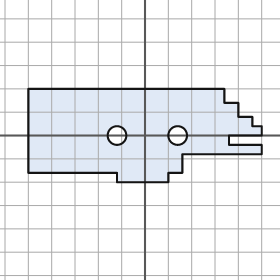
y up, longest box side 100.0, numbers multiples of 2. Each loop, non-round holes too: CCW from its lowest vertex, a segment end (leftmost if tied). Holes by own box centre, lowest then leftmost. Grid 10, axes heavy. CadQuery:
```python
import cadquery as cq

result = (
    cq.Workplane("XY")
    .moveTo(-12.0, -20.0)
    .lineTo(10.0, -20.0)
    .lineTo(10.0, -16.0)
    .lineTo(16.0, -16.0)
    .lineTo(16.0, -8.0)
    .lineTo(50.0, -8.0)
    .lineTo(50.0, -4.0)
    .lineTo(36.0, -4.0)
    .lineTo(36.0, 0.0)
    .lineTo(50.0, 0.0)
    .lineTo(50.0, 4.0)
    .lineTo(46.0, 4.0)
    .lineTo(46.0, 8.0)
    .lineTo(40.0, 8.0)
    .lineTo(40.0, 14.0)
    .lineTo(34.0, 14.0)
    .lineTo(34.0, 20.0)
    .lineTo(-50.0, 20.0)
    .lineTo(-50.0, -16.0)
    .lineTo(-12.0, -16.0)
    .close()
    .moveTo(-12.0, 0.0)
    .circle(4.0)
    .moveTo(14.0, 0.0)
    .circle(4.0)
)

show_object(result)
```